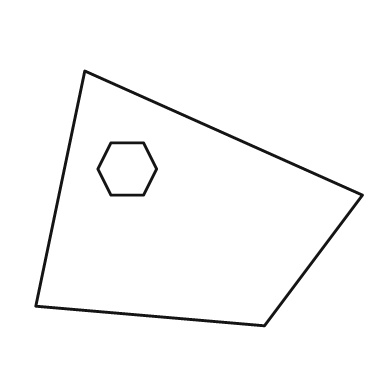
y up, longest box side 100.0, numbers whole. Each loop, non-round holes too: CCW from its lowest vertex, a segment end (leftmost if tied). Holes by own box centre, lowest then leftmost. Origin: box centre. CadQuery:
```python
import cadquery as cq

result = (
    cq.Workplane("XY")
    .moveTo(20.0, -39.0)
    .lineTo(50.0, 1.0)
    .lineTo(-35.0, 39.0)
    .lineTo(-50.0, -33.0)
    .close()
    .moveTo(-27.0, 1.0)
    .lineTo(-17.0, 1.0)
    .lineTo(-13.0, 9.0)
    .lineTo(-17.0, 17.0)
    .lineTo(-27.0, 17.0)
    .lineTo(-31.0, 9.0)
    .close()
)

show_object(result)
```